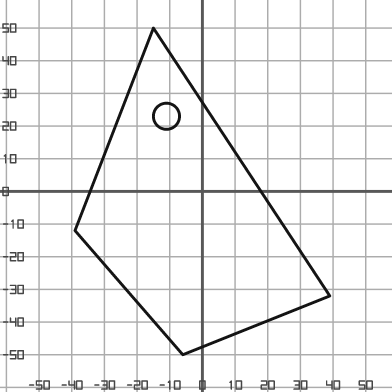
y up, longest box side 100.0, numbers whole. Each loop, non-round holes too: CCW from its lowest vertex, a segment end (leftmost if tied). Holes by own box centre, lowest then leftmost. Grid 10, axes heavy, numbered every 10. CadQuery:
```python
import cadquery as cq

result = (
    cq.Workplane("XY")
    .moveTo(-6.0, -50.0)
    .lineTo(39.0, -32.0)
    .lineTo(-15.0, 50.0)
    .lineTo(-39.0, -12.0)
    .close()
    .moveTo(-11.0, 23.0)
    .circle(4.0)
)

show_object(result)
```